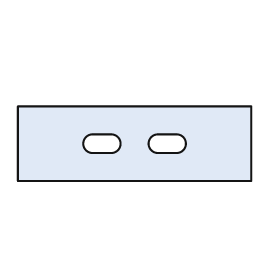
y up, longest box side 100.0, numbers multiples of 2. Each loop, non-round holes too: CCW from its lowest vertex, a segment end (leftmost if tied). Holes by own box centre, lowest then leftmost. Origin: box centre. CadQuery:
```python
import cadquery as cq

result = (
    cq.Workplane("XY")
    .moveTo(-50.0, -16.0)
    .lineTo(50.0, -16.0)
    .lineTo(50.0, 16.0)
    .lineTo(-50.0, 16.0)
    .close()
    .moveTo(-18.0, -4.0)
    .lineTo(-10.0, -4.0)
    .threePointArc((-6.0, 0.0), (-10.0, 4.0))
    .lineTo(-18.0, 4.0)
    .threePointArc((-22.0, 0.0), (-18.0, -4.0))
    .close()
    .moveTo(10.0, -4.0)
    .lineTo(18.0, -4.0)
    .threePointArc((22.0, 0.0), (18.0, 4.0))
    .lineTo(10.0, 4.0)
    .threePointArc((6.0, 0.0), (10.0, -4.0))
    .close()
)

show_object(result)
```